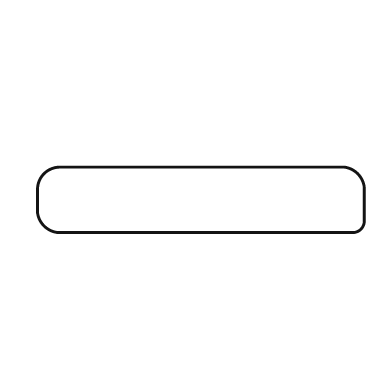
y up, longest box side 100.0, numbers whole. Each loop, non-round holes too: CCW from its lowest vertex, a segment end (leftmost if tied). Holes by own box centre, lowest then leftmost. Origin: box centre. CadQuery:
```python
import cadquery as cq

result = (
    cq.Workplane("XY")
    .moveTo(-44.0, -10.0)
    .lineTo(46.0, -10.0)
    .threePointArc((49.0, -9.0), (50.0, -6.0))
    .lineTo(50.0, 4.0)
    .threePointArc((48.0, 8.0), (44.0, 10.0))
    .lineTo(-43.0, 10.0)
    .threePointArc((-48.0, 8.0), (-50.0, 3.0))
    .lineTo(-50.0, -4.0)
    .threePointArc((-48.0, -8.0), (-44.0, -10.0))
    .close()
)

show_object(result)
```